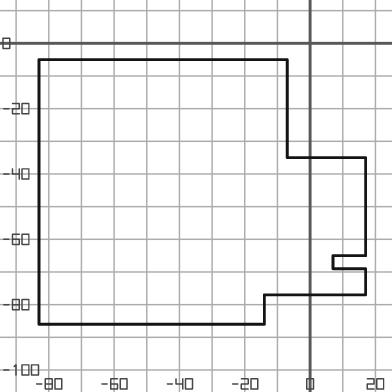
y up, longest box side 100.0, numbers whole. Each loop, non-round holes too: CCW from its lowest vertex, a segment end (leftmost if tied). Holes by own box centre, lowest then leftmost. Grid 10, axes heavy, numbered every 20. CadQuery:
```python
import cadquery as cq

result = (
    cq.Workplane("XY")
    .moveTo(-83.0, -86.0)
    .lineTo(-14.0, -86.0)
    .lineTo(-14.0, -77.0)
    .lineTo(17.0, -77.0)
    .lineTo(17.0, -69.0)
    .lineTo(7.0, -69.0)
    .lineTo(7.0, -65.0)
    .lineTo(17.0, -65.0)
    .lineTo(17.0, -35.0)
    .lineTo(-7.0, -35.0)
    .lineTo(-7.0, -5.0)
    .lineTo(-83.0, -5.0)
    .close()
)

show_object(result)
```